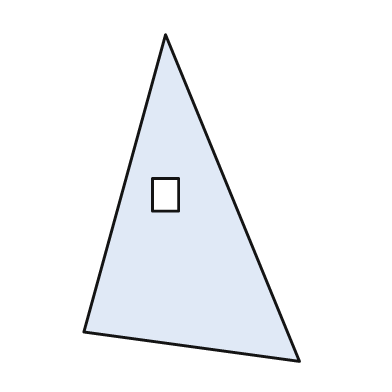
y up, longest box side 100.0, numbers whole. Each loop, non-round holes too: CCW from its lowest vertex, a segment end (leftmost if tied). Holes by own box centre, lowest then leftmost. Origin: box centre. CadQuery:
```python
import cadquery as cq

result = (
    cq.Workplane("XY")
    .moveTo(33.0, -50.0)
    .lineTo(-8.0, 50.0)
    .lineTo(-33.0, -41.0)
    .close()
    .moveTo(-12.0, -4.0)
    .lineTo(-4.0, -4.0)
    .lineTo(-4.0, 6.0)
    .lineTo(-12.0, 6.0)
    .close()
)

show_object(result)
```